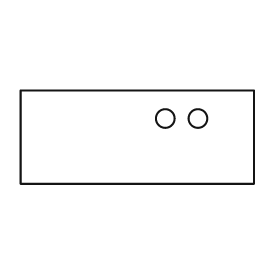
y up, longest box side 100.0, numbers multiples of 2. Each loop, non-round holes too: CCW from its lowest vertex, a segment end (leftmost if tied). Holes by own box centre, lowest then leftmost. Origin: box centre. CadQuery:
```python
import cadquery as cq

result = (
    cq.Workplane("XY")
    .moveTo(-50.0, -20.0)
    .lineTo(50.0, -20.0)
    .lineTo(50.0, 20.0)
    .lineTo(-50.0, 20.0)
    .close()
    .moveTo(12.0, 8.0)
    .circle(4.0)
    .moveTo(26.0, 8.0)
    .circle(4.0)
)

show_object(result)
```